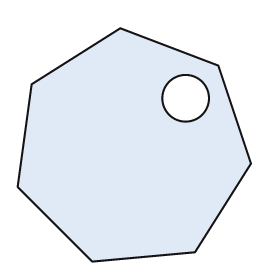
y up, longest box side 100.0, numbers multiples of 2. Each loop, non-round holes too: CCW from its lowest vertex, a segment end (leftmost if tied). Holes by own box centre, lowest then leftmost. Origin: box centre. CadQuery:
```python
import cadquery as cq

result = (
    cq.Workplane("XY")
    .moveTo(-18.0, -50.0)
    .lineTo(26.0, -46.0)
    .lineTo(50.0, -8.0)
    .lineTo(36.0, 34.0)
    .lineTo(-6.0, 50.0)
    .lineTo(-44.0, 26.0)
    .lineTo(-50.0, -18.0)
    .close()
    .moveTo(22.0, 20.0)
    .circle(10.0)
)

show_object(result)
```